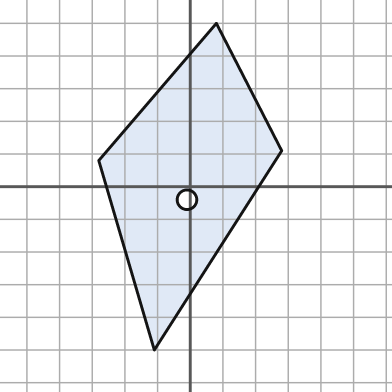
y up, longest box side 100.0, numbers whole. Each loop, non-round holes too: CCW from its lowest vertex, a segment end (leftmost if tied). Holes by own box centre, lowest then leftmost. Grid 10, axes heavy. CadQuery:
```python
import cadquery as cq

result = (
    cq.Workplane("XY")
    .moveTo(-11.0, -50.0)
    .lineTo(28.0, 11.0)
    .lineTo(8.0, 50.0)
    .lineTo(-28.0, 8.0)
    .close()
    .moveTo(-1.0, -4.0)
    .circle(3.0)
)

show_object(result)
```